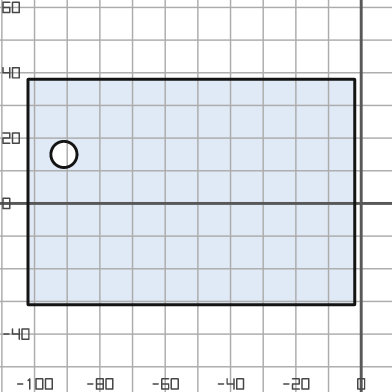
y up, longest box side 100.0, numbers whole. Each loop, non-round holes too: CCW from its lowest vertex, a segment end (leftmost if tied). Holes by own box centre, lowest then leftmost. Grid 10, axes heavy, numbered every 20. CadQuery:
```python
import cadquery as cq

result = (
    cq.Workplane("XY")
    .moveTo(-102.0, -31.0)
    .lineTo(-2.0, -31.0)
    .lineTo(-2.0, 38.0)
    .lineTo(-102.0, 38.0)
    .close()
    .moveTo(-91.0, 15.0)
    .circle(4.0)
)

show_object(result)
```